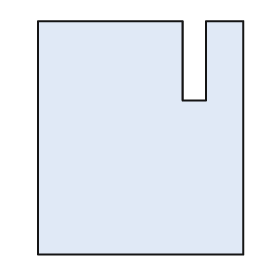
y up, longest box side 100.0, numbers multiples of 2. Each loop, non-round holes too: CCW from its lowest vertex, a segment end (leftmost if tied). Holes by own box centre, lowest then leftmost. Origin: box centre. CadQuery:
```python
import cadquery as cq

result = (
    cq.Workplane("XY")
    .moveTo(-44.0, -50.0)
    .lineTo(44.0, -50.0)
    .lineTo(44.0, 50.0)
    .lineTo(28.0, 50.0)
    .lineTo(28.0, 16.0)
    .lineTo(18.0, 16.0)
    .lineTo(18.0, 50.0)
    .lineTo(-44.0, 50.0)
    .close()
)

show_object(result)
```